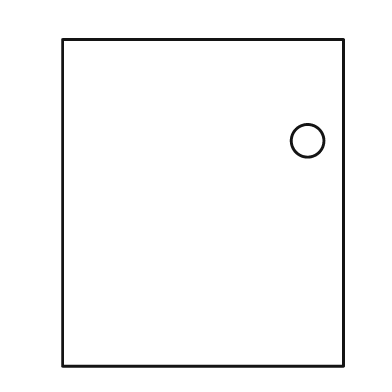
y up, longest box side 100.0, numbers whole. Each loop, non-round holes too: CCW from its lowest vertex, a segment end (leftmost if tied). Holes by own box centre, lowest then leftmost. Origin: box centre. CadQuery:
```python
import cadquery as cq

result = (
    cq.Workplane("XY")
    .moveTo(-43.0, -50.0)
    .lineTo(43.0, -50.0)
    .lineTo(43.0, 50.0)
    .lineTo(-43.0, 50.0)
    .close()
    .moveTo(32.0, 19.0)
    .circle(5.0)
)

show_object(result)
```